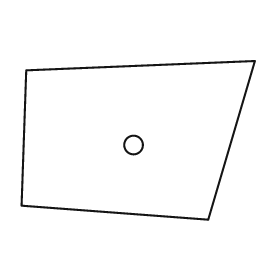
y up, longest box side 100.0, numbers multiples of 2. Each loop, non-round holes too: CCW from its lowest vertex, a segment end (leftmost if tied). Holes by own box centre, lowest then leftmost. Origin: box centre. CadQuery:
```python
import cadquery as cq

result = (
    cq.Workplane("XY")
    .moveTo(30.0, -34.0)
    .lineTo(50.0, 34.0)
    .lineTo(-48.0, 30.0)
    .lineTo(-50.0, -28.0)
    .close()
    .moveTo(-2.0, -2.0)
    .circle(4.0)
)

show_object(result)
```